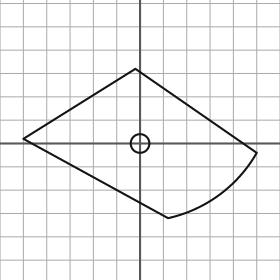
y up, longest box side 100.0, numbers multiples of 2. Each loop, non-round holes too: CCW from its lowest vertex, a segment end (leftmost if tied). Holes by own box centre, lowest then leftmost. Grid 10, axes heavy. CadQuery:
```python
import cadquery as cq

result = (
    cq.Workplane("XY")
    .moveTo(12.0, -32.0)
    .threePointArc((34.0, -22.0), (50.0, -4.0))
    .lineTo(-2.0, 32.0)
    .lineTo(-50.0, 2.0)
    .close()
    .moveTo(0.0, 0.0)
    .circle(4.0)
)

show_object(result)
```